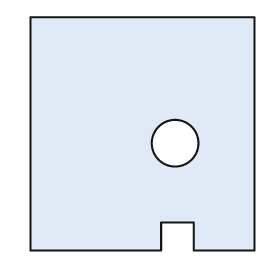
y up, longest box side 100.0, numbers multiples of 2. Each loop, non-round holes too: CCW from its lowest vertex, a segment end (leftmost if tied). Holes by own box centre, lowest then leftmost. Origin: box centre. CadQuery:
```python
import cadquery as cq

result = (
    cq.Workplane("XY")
    .moveTo(-48.0, -50.0)
    .lineTo(8.0, -50.0)
    .lineTo(8.0, -38.0)
    .lineTo(22.0, -38.0)
    .lineTo(22.0, -50.0)
    .lineTo(48.0, -50.0)
    .lineTo(48.0, 50.0)
    .lineTo(-48.0, 50.0)
    .close()
    .moveTo(14.0, -4.0)
    .circle(10.0)
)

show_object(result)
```